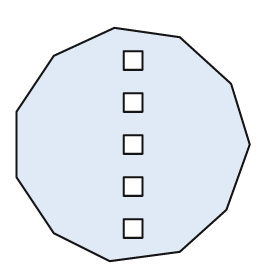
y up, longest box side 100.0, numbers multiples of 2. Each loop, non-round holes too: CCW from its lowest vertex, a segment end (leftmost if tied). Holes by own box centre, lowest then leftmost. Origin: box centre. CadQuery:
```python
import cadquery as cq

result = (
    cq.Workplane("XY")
    .moveTo(-10.0, -50.0)
    .lineTo(20.0, -46.0)
    .lineTo(40.0, -28.0)
    .lineTo(50.0, 0.0)
    .lineTo(42.0, 26.0)
    .lineTo(20.0, 46.0)
    .lineTo(-8.0, 50.0)
    .lineTo(-34.0, 38.0)
    .lineTo(-50.0, 14.0)
    .lineTo(-50.0, -14.0)
    .lineTo(-34.0, -38.0)
    .close()
    .moveTo(-4.0, -40.0)
    .lineTo(4.0, -40.0)
    .lineTo(4.0, -32.0)
    .lineTo(-4.0, -32.0)
    .close()
    .moveTo(-4.0, -22.0)
    .lineTo(4.0, -22.0)
    .lineTo(4.0, -14.0)
    .lineTo(-4.0, -14.0)
    .close()
    .moveTo(-4.0, -4.0)
    .lineTo(4.0, -4.0)
    .lineTo(4.0, 4.0)
    .lineTo(-4.0, 4.0)
    .close()
    .moveTo(-4.0, 14.0)
    .lineTo(4.0, 14.0)
    .lineTo(4.0, 22.0)
    .lineTo(-4.0, 22.0)
    .close()
    .moveTo(-4.0, 32.0)
    .lineTo(4.0, 32.0)
    .lineTo(4.0, 40.0)
    .lineTo(-4.0, 40.0)
    .close()
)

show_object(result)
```